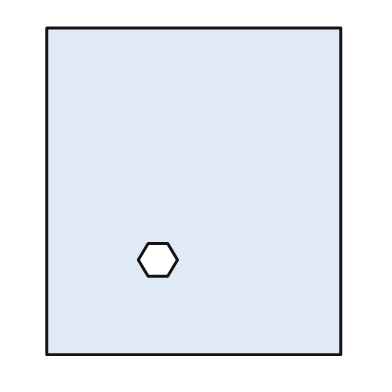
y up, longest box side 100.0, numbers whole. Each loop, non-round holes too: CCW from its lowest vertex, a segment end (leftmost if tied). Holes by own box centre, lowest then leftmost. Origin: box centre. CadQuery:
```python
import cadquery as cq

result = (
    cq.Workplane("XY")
    .moveTo(-45.0, -50.0)
    .lineTo(45.0, -50.0)
    .lineTo(45.0, 50.0)
    .lineTo(-45.0, 50.0)
    .close()
    .moveTo(-14.0, -26.0)
    .lineTo(-8.0, -26.0)
    .lineTo(-5.0, -21.0)
    .lineTo(-8.0, -16.0)
    .lineTo(-14.0, -16.0)
    .lineTo(-17.0, -21.0)
    .close()
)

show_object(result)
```